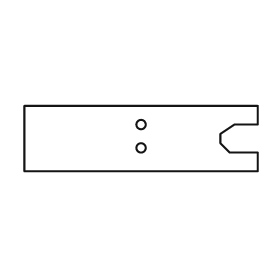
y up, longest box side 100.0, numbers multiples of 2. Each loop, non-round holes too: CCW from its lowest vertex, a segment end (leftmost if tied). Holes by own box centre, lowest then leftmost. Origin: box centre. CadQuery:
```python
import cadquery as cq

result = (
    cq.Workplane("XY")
    .moveTo(-50.0, -14.0)
    .lineTo(50.0, -14.0)
    .lineTo(50.0, -6.0)
    .lineTo(38.0, -6.0)
    .lineTo(34.0, -2.0)
    .lineTo(34.0, 2.0)
    .lineTo(40.0, 6.0)
    .lineTo(50.0, 6.0)
    .lineTo(50.0, 14.0)
    .lineTo(-50.0, 14.0)
    .close()
    .moveTo(0.0, -4.0)
    .circle(2.0)
    .moveTo(0.0, 6.0)
    .circle(2.0)
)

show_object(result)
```